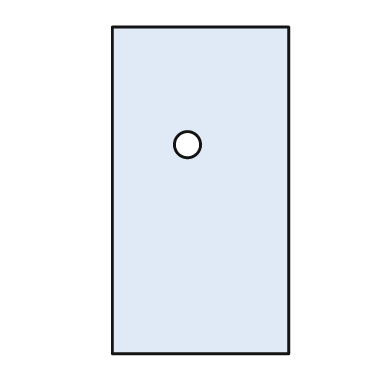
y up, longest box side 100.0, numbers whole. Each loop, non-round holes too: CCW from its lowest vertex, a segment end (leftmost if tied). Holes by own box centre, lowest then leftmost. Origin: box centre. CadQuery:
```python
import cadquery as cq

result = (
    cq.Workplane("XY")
    .moveTo(-27.0, -50.0)
    .lineTo(27.0, -50.0)
    .lineTo(27.0, 50.0)
    .lineTo(-27.0, 50.0)
    .close()
    .moveTo(-4.0, 14.0)
    .circle(4.0)
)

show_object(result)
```